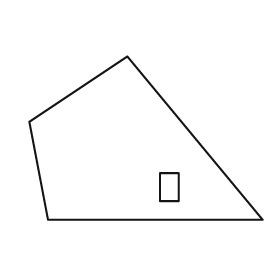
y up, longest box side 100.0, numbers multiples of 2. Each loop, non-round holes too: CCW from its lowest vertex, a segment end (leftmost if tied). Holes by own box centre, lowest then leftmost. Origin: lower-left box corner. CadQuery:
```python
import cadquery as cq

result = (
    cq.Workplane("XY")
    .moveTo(8.0, 0.0)
    .lineTo(100.0, 0.0)
    .lineTo(42.0, 70.0)
    .lineTo(0.0, 42.0)
    .close()
    .moveTo(56.0, 8.0)
    .lineTo(64.0, 8.0)
    .lineTo(64.0, 20.0)
    .lineTo(56.0, 20.0)
    .close()
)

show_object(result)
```